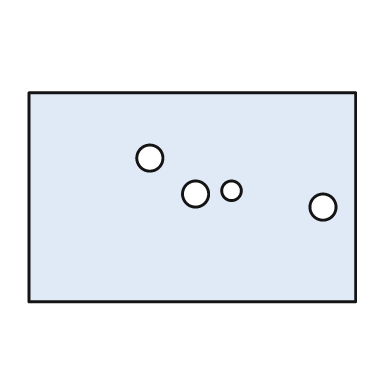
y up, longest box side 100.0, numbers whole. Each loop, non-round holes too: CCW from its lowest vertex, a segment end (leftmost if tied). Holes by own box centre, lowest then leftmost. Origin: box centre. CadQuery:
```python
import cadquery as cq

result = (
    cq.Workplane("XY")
    .moveTo(-50.0, -32.0)
    .lineTo(50.0, -32.0)
    .lineTo(50.0, 32.0)
    .lineTo(-50.0, 32.0)
    .close()
    .moveTo(40.0, -3.0)
    .circle(4.0)
    .moveTo(1.0, 1.0)
    .circle(4.0)
    .moveTo(12.0, 2.0)
    .circle(3.0)
    .moveTo(-13.0, 12.0)
    .circle(4.0)
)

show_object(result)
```